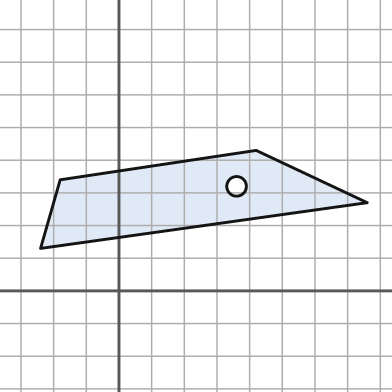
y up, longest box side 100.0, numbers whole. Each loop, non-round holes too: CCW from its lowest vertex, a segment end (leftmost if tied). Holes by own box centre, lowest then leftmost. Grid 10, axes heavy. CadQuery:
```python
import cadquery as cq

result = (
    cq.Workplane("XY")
    .moveTo(-24.0, 13.0)
    .lineTo(76.0, 27.0)
    .lineTo(42.0, 43.0)
    .lineTo(-18.0, 34.0)
    .close()
    .moveTo(36.0, 32.0)
    .circle(3.0)
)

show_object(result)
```